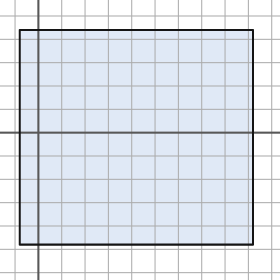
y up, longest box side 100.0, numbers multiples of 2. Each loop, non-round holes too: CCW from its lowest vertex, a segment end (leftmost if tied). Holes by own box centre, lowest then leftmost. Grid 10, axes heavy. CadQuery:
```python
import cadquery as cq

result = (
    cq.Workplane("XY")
    .moveTo(-8.0, -48.0)
    .lineTo(92.0, -48.0)
    .lineTo(92.0, 44.0)
    .lineTo(-8.0, 44.0)
    .close()
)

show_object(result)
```